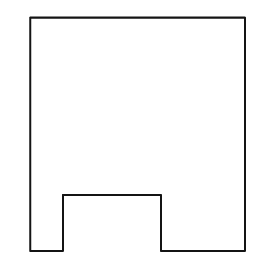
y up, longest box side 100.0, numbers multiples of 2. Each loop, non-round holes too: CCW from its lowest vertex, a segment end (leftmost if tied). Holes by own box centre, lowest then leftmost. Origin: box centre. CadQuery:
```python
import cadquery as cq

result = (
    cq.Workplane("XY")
    .moveTo(-46.0, -50.0)
    .lineTo(-32.0, -50.0)
    .lineTo(-32.0, -26.0)
    .lineTo(10.0, -26.0)
    .lineTo(10.0, -50.0)
    .lineTo(46.0, -50.0)
    .lineTo(46.0, 50.0)
    .lineTo(-46.0, 50.0)
    .close()
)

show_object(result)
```